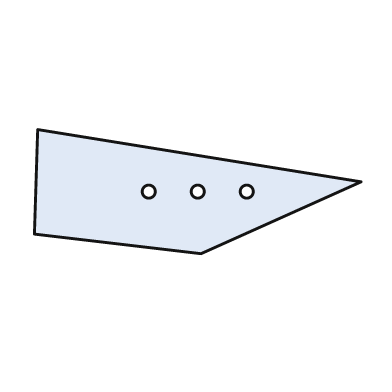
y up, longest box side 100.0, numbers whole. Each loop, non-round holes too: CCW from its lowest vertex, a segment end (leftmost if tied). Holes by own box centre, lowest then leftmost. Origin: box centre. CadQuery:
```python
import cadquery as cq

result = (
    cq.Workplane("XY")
    .moveTo(1.0, -19.0)
    .lineTo(50.0, 3.0)
    .lineTo(-49.0, 19.0)
    .lineTo(-50.0, -13.0)
    .close()
    .moveTo(-15.0, 0.0)
    .circle(2.0)
    .moveTo(0.0, 0.0)
    .circle(2.0)
    .moveTo(15.0, 0.0)
    .circle(2.0)
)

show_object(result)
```